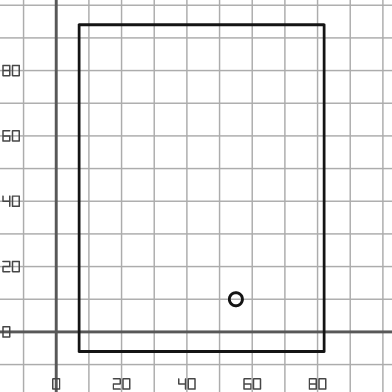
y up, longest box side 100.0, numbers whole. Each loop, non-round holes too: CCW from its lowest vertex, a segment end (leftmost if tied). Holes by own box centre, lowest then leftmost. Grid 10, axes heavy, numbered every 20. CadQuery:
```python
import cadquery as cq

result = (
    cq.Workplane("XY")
    .moveTo(7.0, -6.0)
    .lineTo(82.0, -6.0)
    .lineTo(82.0, 94.0)
    .lineTo(7.0, 94.0)
    .close()
    .moveTo(55.0, 10.0)
    .circle(2.0)
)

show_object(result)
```